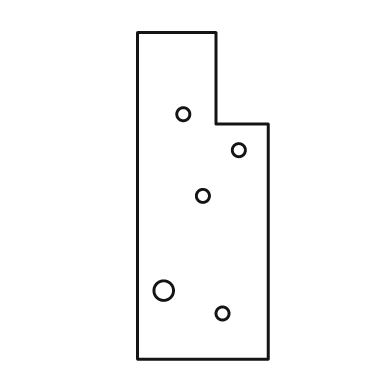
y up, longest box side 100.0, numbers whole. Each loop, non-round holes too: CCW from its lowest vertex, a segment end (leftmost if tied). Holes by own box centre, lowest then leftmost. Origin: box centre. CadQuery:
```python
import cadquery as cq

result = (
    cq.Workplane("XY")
    .moveTo(-20.0, -50.0)
    .lineTo(20.0, -50.0)
    .lineTo(20.0, 22.0)
    .lineTo(4.0, 22.0)
    .lineTo(4.0, 50.0)
    .lineTo(-20.0, 50.0)
    .close()
    .moveTo(6.0, -36.0)
    .circle(2.0)
    .moveTo(-12.0, -29.0)
    .circle(3.0)
    .moveTo(0.0, 0.0)
    .circle(2.0)
    .moveTo(11.0, 14.0)
    .circle(2.0)
    .moveTo(-6.0, 25.0)
    .circle(2.0)
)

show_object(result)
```